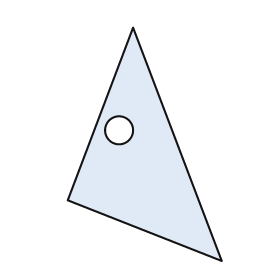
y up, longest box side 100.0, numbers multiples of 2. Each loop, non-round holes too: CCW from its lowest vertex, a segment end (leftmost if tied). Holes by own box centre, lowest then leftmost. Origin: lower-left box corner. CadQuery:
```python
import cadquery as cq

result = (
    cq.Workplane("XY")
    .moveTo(66.0, 0.0)
    .lineTo(28.0, 100.0)
    .lineTo(0.0, 26.0)
    .close()
    .moveTo(22.0, 56.0)
    .circle(6.0)
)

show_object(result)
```